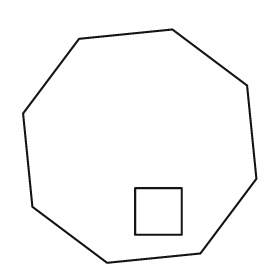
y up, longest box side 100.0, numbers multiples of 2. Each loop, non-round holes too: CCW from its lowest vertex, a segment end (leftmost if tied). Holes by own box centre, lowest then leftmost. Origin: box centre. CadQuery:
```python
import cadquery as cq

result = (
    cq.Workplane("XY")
    .moveTo(-14.0, -50.0)
    .lineTo(26.0, -46.0)
    .lineTo(50.0, -14.0)
    .lineTo(46.0, 26.0)
    .lineTo(14.0, 50.0)
    .lineTo(-26.0, 46.0)
    .lineTo(-50.0, 14.0)
    .lineTo(-46.0, -26.0)
    .close()
    .moveTo(-2.0, -38.0)
    .lineTo(18.0, -38.0)
    .lineTo(18.0, -18.0)
    .lineTo(-2.0, -18.0)
    .close()
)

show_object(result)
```